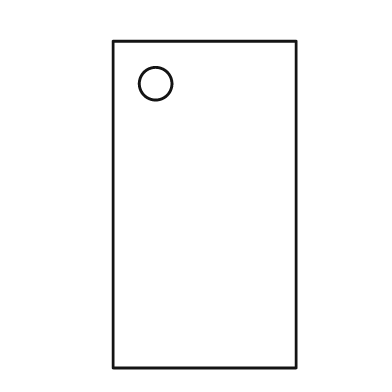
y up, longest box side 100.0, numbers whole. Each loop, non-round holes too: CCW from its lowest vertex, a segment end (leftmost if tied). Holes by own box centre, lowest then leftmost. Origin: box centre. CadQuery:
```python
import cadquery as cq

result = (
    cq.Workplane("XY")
    .moveTo(-28.0, -50.0)
    .lineTo(28.0, -50.0)
    .lineTo(28.0, 50.0)
    .lineTo(-28.0, 50.0)
    .close()
    .moveTo(-15.0, 37.0)
    .circle(5.0)
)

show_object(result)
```